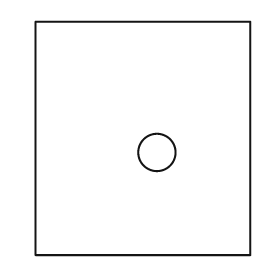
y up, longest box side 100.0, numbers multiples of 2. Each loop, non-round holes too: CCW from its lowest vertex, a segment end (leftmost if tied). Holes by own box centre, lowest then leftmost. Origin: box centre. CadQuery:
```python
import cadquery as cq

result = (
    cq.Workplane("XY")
    .moveTo(-46.0, -50.0)
    .lineTo(46.0, -50.0)
    .lineTo(46.0, 50.0)
    .lineTo(-46.0, 50.0)
    .close()
    .moveTo(6.0, -6.0)
    .circle(8.0)
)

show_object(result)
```